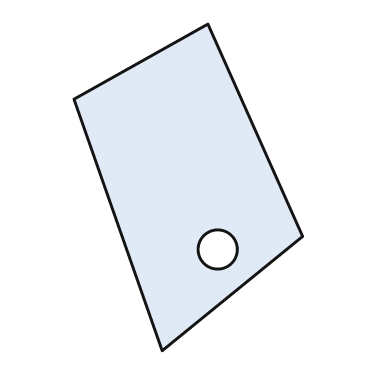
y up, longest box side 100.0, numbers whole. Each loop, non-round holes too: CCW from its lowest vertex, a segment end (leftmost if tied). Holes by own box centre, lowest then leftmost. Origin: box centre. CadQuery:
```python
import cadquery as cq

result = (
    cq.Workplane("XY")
    .moveTo(-8.0, -50.0)
    .lineTo(35.0, -15.0)
    .lineTo(6.0, 50.0)
    .lineTo(-35.0, 27.0)
    .close()
    .moveTo(9.0, -19.0)
    .circle(6.0)
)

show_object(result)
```